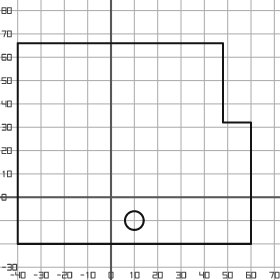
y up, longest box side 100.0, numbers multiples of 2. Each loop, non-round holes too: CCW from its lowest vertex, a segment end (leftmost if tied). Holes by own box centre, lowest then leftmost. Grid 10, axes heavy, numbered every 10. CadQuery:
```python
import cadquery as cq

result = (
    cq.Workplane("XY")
    .moveTo(-40.0, -20.0)
    .lineTo(60.0, -20.0)
    .lineTo(60.0, 32.0)
    .lineTo(48.0, 32.0)
    .lineTo(48.0, 66.0)
    .lineTo(-40.0, 66.0)
    .close()
    .moveTo(10.0, -10.0)
    .circle(4.0)
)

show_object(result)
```